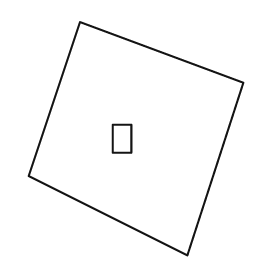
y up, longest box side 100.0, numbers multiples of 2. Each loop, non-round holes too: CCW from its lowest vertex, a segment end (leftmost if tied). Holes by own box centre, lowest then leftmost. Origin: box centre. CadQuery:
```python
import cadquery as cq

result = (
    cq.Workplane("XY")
    .moveTo(22.0, -50.0)
    .lineTo(46.0, 24.0)
    .lineTo(-24.0, 50.0)
    .lineTo(-46.0, -16.0)
    .close()
    .moveTo(-10.0, -6.0)
    .lineTo(-2.0, -6.0)
    .lineTo(-2.0, 6.0)
    .lineTo(-10.0, 6.0)
    .close()
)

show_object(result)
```